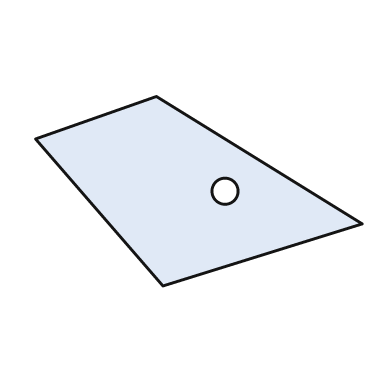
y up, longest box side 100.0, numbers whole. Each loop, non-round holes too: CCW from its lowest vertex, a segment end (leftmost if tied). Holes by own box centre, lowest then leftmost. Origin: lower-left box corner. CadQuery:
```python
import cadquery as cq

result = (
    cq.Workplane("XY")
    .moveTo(39.0, 0.0)
    .lineTo(100.0, 19.0)
    .lineTo(37.0, 58.0)
    .lineTo(0.0, 45.0)
    .close()
    .moveTo(58.0, 29.0)
    .circle(4.0)
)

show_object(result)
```